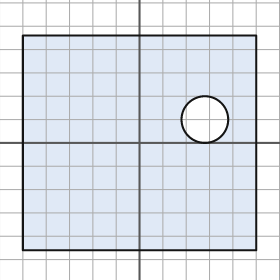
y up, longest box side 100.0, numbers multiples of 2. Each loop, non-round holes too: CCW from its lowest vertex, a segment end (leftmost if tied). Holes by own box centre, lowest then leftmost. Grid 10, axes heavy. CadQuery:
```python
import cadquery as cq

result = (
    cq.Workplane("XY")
    .moveTo(-50.0, -46.0)
    .lineTo(50.0, -46.0)
    .lineTo(50.0, 46.0)
    .lineTo(-50.0, 46.0)
    .close()
    .moveTo(28.0, 10.0)
    .circle(10.0)
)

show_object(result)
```